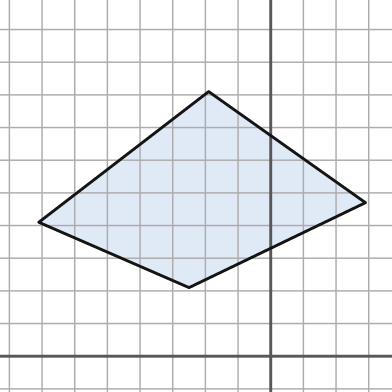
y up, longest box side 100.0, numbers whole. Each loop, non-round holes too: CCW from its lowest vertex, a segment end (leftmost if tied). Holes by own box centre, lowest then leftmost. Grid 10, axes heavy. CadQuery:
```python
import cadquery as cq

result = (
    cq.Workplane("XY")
    .moveTo(-25.0, 21.0)
    .lineTo(29.0, 47.0)
    .lineTo(-19.0, 81.0)
    .lineTo(-71.0, 41.0)
    .close()
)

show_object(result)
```